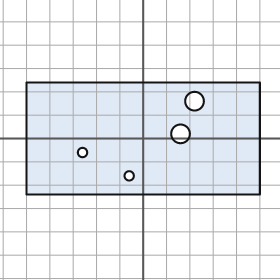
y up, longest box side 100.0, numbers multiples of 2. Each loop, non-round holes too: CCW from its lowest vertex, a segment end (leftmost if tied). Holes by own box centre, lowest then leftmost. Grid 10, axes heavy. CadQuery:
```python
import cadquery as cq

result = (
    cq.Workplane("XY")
    .moveTo(-50.0, -24.0)
    .lineTo(50.0, -24.0)
    .lineTo(50.0, 24.0)
    .lineTo(-50.0, 24.0)
    .close()
    .moveTo(-6.0, -16.0)
    .circle(2.0)
    .moveTo(-26.0, -6.0)
    .circle(2.0)
    .moveTo(16.0, 2.0)
    .circle(4.0)
    .moveTo(22.0, 16.0)
    .circle(4.0)
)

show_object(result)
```